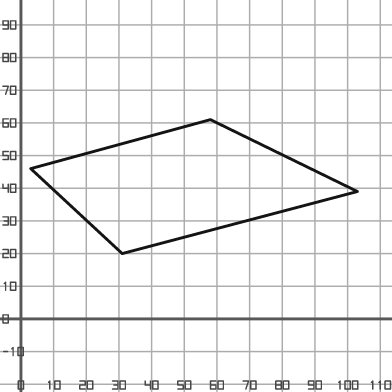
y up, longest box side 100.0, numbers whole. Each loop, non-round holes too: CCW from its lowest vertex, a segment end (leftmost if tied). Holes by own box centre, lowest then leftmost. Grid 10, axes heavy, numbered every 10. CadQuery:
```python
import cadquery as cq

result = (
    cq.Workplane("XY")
    .moveTo(31.0, 20.0)
    .lineTo(103.0, 39.0)
    .lineTo(58.0, 61.0)
    .lineTo(3.0, 46.0)
    .close()
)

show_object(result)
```